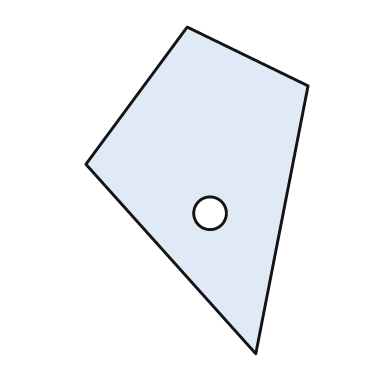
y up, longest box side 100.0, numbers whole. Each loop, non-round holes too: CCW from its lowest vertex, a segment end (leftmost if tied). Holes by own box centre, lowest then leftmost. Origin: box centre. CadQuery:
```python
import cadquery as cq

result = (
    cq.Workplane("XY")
    .moveTo(18.0, -50.0)
    .lineTo(34.0, 32.0)
    .lineTo(-3.0, 50.0)
    .lineTo(-34.0, 8.0)
    .close()
    .moveTo(4.0, -7.0)
    .circle(5.0)
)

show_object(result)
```